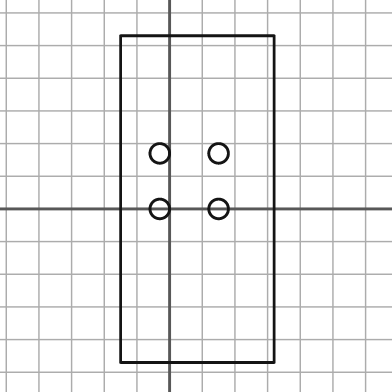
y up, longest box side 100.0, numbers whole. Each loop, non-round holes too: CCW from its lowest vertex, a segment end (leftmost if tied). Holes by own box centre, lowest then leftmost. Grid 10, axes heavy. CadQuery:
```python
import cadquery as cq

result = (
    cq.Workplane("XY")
    .moveTo(-15.0, -47.0)
    .lineTo(32.0, -47.0)
    .lineTo(32.0, 53.0)
    .lineTo(-15.0, 53.0)
    .close()
    .moveTo(-3.0, 0.0)
    .circle(3.0)
    .moveTo(15.0, 0.0)
    .circle(3.0)
    .moveTo(-3.0, 17.0)
    .circle(3.0)
    .moveTo(15.0, 17.0)
    .circle(3.0)
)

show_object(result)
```